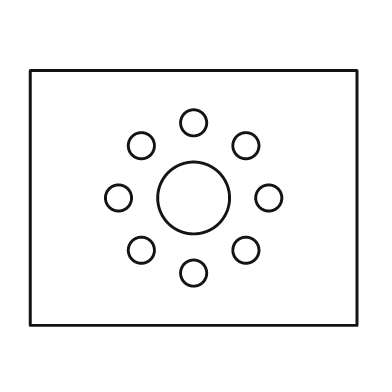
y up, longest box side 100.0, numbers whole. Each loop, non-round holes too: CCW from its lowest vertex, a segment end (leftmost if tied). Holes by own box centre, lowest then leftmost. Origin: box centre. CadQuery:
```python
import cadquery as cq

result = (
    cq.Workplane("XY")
    .moveTo(-50.0, -39.0)
    .lineTo(50.0, -39.0)
    .lineTo(50.0, 39.0)
    .lineTo(-50.0, 39.0)
    .close()
    .moveTo(0.0, -23.0)
    .circle(4.0)
    .moveTo(-16.0, -16.0)
    .circle(4.0)
    .moveTo(16.0, -16.0)
    .circle(4.0)
    .moveTo(-23.0, 0.0)
    .circle(4.0)
    .moveTo(0.0, 0.0)
    .circle(11.0)
    .moveTo(23.0, 0.0)
    .circle(4.0)
    .moveTo(-16.0, 16.0)
    .circle(4.0)
    .moveTo(16.0, 16.0)
    .circle(4.0)
    .moveTo(0.0, 23.0)
    .circle(4.0)
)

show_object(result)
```